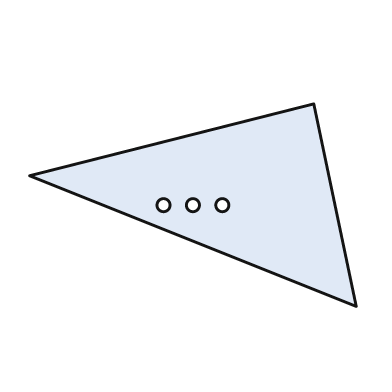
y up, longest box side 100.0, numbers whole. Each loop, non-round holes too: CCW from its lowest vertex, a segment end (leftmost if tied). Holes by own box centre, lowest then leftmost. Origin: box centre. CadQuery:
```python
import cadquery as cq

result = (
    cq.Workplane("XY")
    .moveTo(50.0, -31.0)
    .lineTo(37.0, 31.0)
    .lineTo(-50.0, 9.0)
    .close()
    .moveTo(-9.0, 0.0)
    .circle(2.0)
    .moveTo(0.0, 0.0)
    .circle(2.0)
    .moveTo(9.0, 0.0)
    .circle(2.0)
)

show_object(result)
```